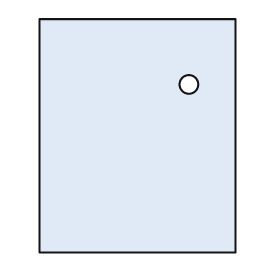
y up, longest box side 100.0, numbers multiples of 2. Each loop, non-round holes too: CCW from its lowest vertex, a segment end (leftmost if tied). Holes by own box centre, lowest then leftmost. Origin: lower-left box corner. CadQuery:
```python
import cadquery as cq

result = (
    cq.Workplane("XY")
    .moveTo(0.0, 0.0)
    .lineTo(84.0, 0.0)
    .lineTo(84.0, 100.0)
    .lineTo(0.0, 100.0)
    .close()
    .moveTo(64.0, 72.0)
    .circle(4.0)
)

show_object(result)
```